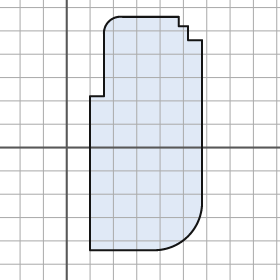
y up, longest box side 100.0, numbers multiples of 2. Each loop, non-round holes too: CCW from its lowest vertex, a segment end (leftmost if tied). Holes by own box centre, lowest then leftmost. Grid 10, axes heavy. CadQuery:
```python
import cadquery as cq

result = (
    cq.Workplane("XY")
    .moveTo(10.0, -44.0)
    .lineTo(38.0, -44.0)
    .threePointArc((52.0, -38.0), (58.0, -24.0))
    .lineTo(58.0, 46.0)
    .lineTo(52.0, 46.0)
    .lineTo(52.0, 52.0)
    .lineTo(48.0, 52.0)
    .lineTo(48.0, 56.0)
    .lineTo(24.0, 56.0)
    .threePointArc((18.0, 54.0), (16.0, 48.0))
    .lineTo(16.0, 22.0)
    .lineTo(10.0, 22.0)
    .close()
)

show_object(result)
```